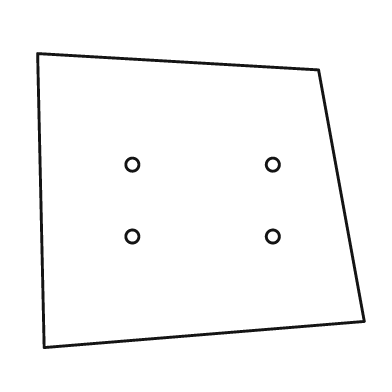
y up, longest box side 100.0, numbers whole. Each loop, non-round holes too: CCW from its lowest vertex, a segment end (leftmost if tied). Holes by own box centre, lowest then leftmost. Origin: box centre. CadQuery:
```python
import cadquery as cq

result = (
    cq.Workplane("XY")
    .moveTo(-48.0, -45.0)
    .lineTo(50.0, -37.0)
    .lineTo(36.0, 40.0)
    .lineTo(-50.0, 45.0)
    .close()
    .moveTo(-21.0, -11.0)
    .circle(2.0)
    .moveTo(22.0, -11.0)
    .circle(2.0)
    .moveTo(-21.0, 11.0)
    .circle(2.0)
    .moveTo(22.0, 11.0)
    .circle(2.0)
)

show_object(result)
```